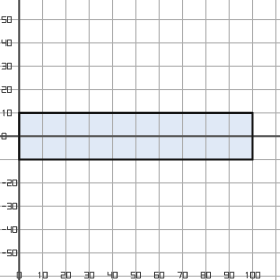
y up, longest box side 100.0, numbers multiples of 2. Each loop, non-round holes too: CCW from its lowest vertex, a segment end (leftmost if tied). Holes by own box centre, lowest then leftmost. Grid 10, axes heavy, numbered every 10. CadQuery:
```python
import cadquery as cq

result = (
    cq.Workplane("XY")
    .moveTo(0.0, -10.0)
    .lineTo(100.0, -10.0)
    .lineTo(100.0, 10.0)
    .lineTo(0.0, 10.0)
    .close()
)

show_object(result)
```